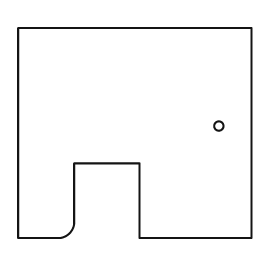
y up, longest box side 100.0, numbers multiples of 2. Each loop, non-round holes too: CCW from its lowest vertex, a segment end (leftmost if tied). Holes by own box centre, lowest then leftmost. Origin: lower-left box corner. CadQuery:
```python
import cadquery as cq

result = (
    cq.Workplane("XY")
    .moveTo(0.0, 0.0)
    .lineTo(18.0, 0.0)
    .threePointArc((22.0, 2.0), (24.0, 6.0))
    .lineTo(24.0, 32.0)
    .lineTo(52.0, 32.0)
    .lineTo(52.0, 0.0)
    .lineTo(100.0, 0.0)
    .lineTo(100.0, 90.0)
    .lineTo(0.0, 90.0)
    .close()
    .moveTo(86.0, 48.0)
    .circle(2.0)
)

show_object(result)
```